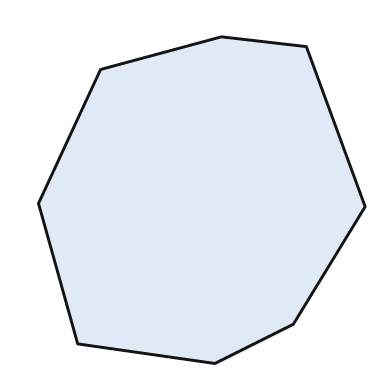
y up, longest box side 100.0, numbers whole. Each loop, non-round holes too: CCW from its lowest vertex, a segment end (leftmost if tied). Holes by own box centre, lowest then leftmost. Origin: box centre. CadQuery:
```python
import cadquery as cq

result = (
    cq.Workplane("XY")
    .moveTo(4.0, -50.0)
    .lineTo(28.0, -38.0)
    .lineTo(50.0, -2.0)
    .lineTo(32.0, 47.0)
    .lineTo(6.0, 50.0)
    .lineTo(-31.0, 40.0)
    .lineTo(-50.0, -1.0)
    .lineTo(-38.0, -44.0)
    .close()
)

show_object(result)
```